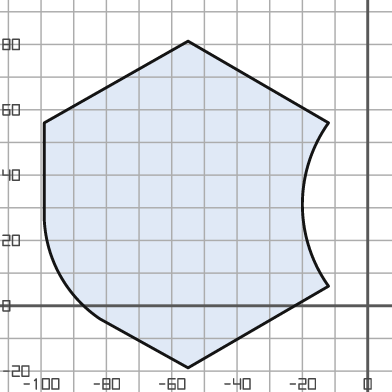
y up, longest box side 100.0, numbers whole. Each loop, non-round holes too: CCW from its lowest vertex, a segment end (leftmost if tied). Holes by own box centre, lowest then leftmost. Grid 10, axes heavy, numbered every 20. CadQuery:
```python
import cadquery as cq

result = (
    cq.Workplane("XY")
    .moveTo(-55.0, -19.0)
    .lineTo(-12.0, 6.0)
    .threePointArc((-20.0, 31.0), (-12.0, 56.0))
    .lineTo(-55.0, 81.0)
    .lineTo(-99.0, 56.0)
    .lineTo(-99.0, 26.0)
    .threePointArc((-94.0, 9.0), (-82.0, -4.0))
    .close()
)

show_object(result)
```